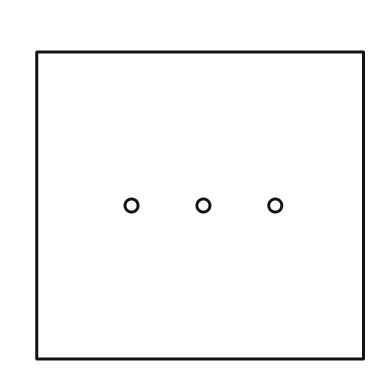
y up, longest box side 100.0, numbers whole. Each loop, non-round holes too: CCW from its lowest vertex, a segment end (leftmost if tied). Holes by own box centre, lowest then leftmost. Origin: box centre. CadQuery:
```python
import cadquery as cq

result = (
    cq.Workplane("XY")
    .moveTo(-50.0, -47.0)
    .lineTo(50.0, -47.0)
    .lineTo(50.0, 47.0)
    .lineTo(-50.0, 47.0)
    .close()
    .moveTo(-21.0, 0.0)
    .circle(2.0)
    .moveTo(1.0, 0.0)
    .circle(2.0)
    .moveTo(23.0, 0.0)
    .circle(2.0)
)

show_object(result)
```